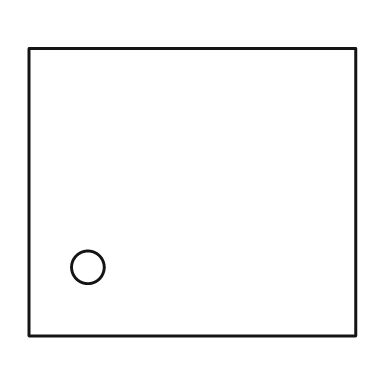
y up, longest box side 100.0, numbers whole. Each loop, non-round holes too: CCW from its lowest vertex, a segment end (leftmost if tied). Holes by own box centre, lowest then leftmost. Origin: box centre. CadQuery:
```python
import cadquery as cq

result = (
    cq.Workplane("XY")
    .moveTo(-50.0, -44.0)
    .lineTo(50.0, -44.0)
    .lineTo(50.0, 44.0)
    .lineTo(-50.0, 44.0)
    .close()
    .moveTo(-32.0, -23.0)
    .circle(5.0)
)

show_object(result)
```